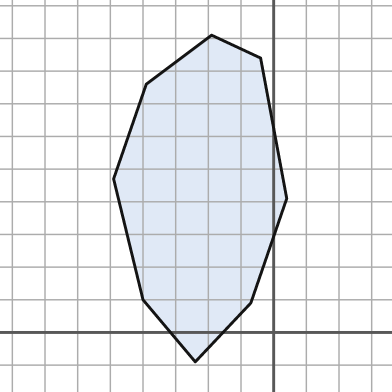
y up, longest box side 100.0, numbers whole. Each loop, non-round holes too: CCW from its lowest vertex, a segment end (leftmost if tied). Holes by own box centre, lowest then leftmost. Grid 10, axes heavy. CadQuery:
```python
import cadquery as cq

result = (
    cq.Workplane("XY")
    .moveTo(-24.0, -9.0)
    .lineTo(-7.0, 9.0)
    .lineTo(4.0, 41.0)
    .lineTo(-4.0, 84.0)
    .lineTo(-19.0, 91.0)
    .lineTo(-39.0, 76.0)
    .lineTo(-49.0, 47.0)
    .lineTo(-40.0, 10.0)
    .close()
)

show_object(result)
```